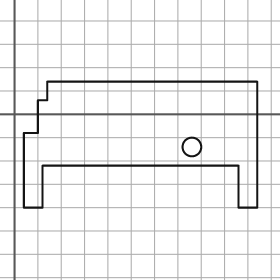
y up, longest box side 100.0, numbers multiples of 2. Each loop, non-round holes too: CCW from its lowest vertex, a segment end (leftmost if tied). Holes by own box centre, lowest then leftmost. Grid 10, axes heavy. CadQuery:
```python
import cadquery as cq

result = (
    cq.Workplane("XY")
    .moveTo(4.0, -40.0)
    .lineTo(12.0, -40.0)
    .lineTo(12.0, -22.0)
    .lineTo(96.0, -22.0)
    .lineTo(96.0, -40.0)
    .lineTo(104.0, -40.0)
    .lineTo(104.0, 14.0)
    .lineTo(14.0, 14.0)
    .lineTo(14.0, 6.0)
    .lineTo(10.0, 6.0)
    .lineTo(10.0, -8.0)
    .lineTo(4.0, -8.0)
    .close()
    .moveTo(76.0, -14.0)
    .circle(4.0)
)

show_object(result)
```